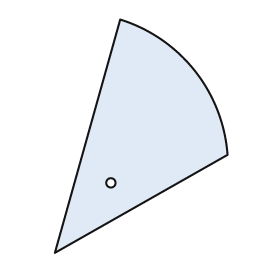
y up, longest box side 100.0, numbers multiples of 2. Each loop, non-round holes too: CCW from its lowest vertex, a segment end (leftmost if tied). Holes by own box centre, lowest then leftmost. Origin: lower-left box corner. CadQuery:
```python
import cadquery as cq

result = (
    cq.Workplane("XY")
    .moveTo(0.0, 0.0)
    .lineTo(74.0, 42.0)
    .threePointArc((60.0, 78.0), (28.0, 100.0))
    .close()
    .moveTo(24.0, 30.0)
    .circle(2.0)
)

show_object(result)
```